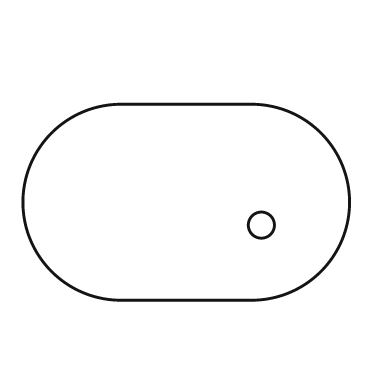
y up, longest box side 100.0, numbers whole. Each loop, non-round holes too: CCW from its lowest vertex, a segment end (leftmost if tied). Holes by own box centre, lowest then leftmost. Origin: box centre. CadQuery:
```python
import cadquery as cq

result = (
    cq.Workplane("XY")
    .moveTo(-20.0, -30.0)
    .lineTo(20.0, -30.0)
    .threePointArc((50.0, 0.0), (20.0, 30.0))
    .lineTo(-20.0, 30.0)
    .threePointArc((-50.0, 0.0), (-20.0, -30.0))
    .close()
    .moveTo(23.0, -7.0)
    .circle(4.0)
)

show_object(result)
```